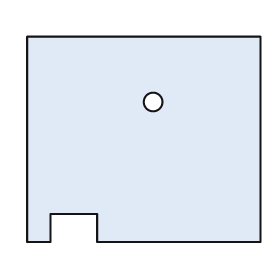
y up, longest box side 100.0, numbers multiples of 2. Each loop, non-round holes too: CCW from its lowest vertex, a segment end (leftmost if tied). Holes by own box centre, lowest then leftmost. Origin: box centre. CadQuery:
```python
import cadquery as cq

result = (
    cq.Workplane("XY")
    .moveTo(-50.0, -44.0)
    .lineTo(-40.0, -44.0)
    .lineTo(-40.0, -32.0)
    .lineTo(-20.0, -32.0)
    .lineTo(-20.0, -44.0)
    .lineTo(50.0, -44.0)
    .lineTo(50.0, 44.0)
    .lineTo(-50.0, 44.0)
    .close()
    .moveTo(4.0, 16.0)
    .circle(4.0)
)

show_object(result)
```